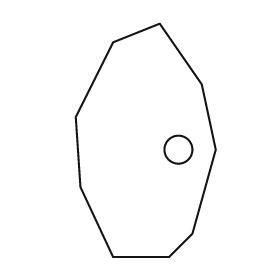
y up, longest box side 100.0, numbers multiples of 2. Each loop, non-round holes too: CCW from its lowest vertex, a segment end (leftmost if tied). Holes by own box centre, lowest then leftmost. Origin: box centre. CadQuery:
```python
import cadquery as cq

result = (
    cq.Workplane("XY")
    .moveTo(-14.0, -50.0)
    .lineTo(10.0, -50.0)
    .lineTo(20.0, -40.0)
    .lineTo(30.0, -4.0)
    .lineTo(24.0, 24.0)
    .lineTo(6.0, 50.0)
    .lineTo(-14.0, 42.0)
    .lineTo(-30.0, 10.0)
    .lineTo(-28.0, -20.0)
    .close()
    .moveTo(14.0, -4.0)
    .circle(6.0)
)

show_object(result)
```